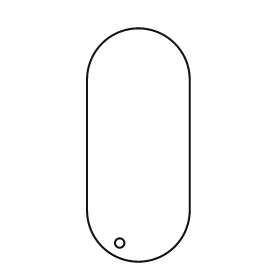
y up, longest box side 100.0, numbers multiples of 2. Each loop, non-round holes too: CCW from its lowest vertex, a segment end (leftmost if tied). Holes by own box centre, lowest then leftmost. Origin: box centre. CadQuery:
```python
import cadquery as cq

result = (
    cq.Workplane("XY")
    .moveTo(-22.0, -28.0)
    .threePointArc((0.0, -50.0), (22.0, -28.0))
    .lineTo(22.0, 28.0)
    .threePointArc((0.0, 50.0), (-22.0, 28.0))
    .close()
    .moveTo(-8.0, -42.0)
    .circle(2.0)
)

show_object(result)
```